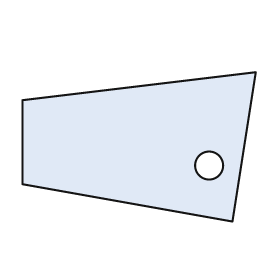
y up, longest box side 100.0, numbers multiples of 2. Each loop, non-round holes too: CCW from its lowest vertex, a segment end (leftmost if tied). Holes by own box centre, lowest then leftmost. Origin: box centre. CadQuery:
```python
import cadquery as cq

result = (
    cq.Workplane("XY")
    .moveTo(40.0, -32.0)
    .lineTo(50.0, 32.0)
    .lineTo(-50.0, 20.0)
    .lineTo(-50.0, -16.0)
    .close()
    .moveTo(30.0, -8.0)
    .circle(6.0)
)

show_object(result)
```